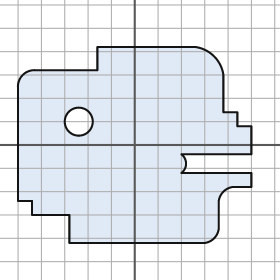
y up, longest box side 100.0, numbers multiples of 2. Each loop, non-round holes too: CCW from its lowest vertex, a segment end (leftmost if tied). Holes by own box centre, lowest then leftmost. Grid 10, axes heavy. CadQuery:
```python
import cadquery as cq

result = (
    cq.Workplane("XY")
    .moveTo(-28.0, -42.0)
    .lineTo(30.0, -42.0)
    .threePointArc((34.0, -40.0), (36.0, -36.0))
    .lineTo(36.0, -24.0)
    .threePointArc((38.0, -20.0), (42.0, -18.0))
    .lineTo(50.0, -18.0)
    .lineTo(50.0, -12.0)
    .lineTo(20.0, -12.0)
    .threePointArc((22.0, -8.0), (20.0, -4.0))
    .lineTo(50.0, -4.0)
    .lineTo(50.0, 8.0)
    .lineTo(44.0, 8.0)
    .lineTo(44.0, 14.0)
    .lineTo(38.0, 14.0)
    .lineTo(38.0, 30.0)
    .threePointArc((34.0, 38.0), (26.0, 42.0))
    .lineTo(-16.0, 42.0)
    .lineTo(-16.0, 32.0)
    .lineTo(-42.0, 32.0)
    .threePointArc((-48.0, 30.0), (-50.0, 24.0))
    .lineTo(-50.0, -24.0)
    .lineTo(-44.0, -24.0)
    .lineTo(-44.0, -30.0)
    .lineTo(-28.0, -30.0)
    .close()
    .moveTo(-24.0, 10.0)
    .circle(6.0)
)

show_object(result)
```